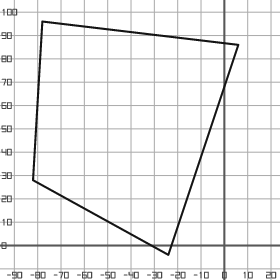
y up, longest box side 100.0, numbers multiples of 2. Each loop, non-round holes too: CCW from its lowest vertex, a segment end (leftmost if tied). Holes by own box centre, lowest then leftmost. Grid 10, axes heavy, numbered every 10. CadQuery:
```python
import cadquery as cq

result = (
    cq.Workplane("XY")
    .moveTo(-24.0, -4.0)
    .lineTo(6.0, 86.0)
    .lineTo(-78.0, 96.0)
    .lineTo(-82.0, 28.0)
    .close()
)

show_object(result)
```